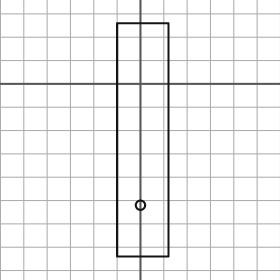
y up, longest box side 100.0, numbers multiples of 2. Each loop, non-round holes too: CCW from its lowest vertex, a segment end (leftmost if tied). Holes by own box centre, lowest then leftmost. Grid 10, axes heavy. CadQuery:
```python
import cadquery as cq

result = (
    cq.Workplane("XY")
    .moveTo(-10.0, -74.0)
    .lineTo(12.0, -74.0)
    .lineTo(12.0, 26.0)
    .lineTo(-10.0, 26.0)
    .close()
    .moveTo(0.0, -52.0)
    .circle(2.0)
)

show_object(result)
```